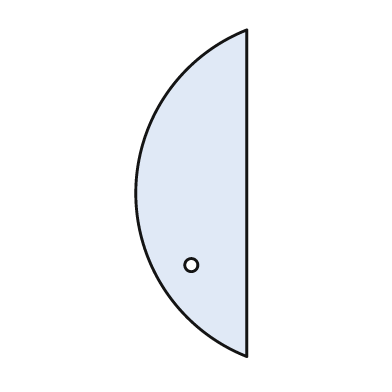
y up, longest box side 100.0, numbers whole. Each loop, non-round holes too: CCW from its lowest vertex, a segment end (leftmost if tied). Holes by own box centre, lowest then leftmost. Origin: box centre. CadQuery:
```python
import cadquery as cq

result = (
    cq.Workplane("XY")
    .moveTo(17.0, -50.0)
    .lineTo(17.0, 50.0)
    .threePointArc((-17.0, 0.0), (17.0, -50.0))
    .close()
    .moveTo(0.0, -22.0)
    .circle(2.0)
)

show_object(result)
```